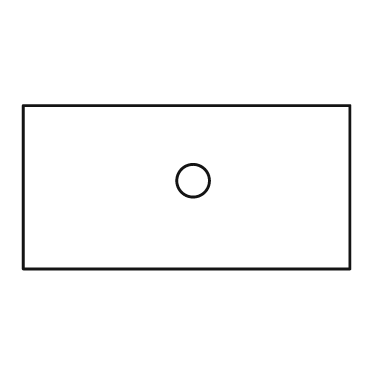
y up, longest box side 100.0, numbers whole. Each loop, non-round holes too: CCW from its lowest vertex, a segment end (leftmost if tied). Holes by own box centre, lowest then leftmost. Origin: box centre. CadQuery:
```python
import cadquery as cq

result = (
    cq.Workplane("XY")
    .moveTo(-50.0, -25.0)
    .lineTo(50.0, -25.0)
    .lineTo(50.0, 25.0)
    .lineTo(-50.0, 25.0)
    .close()
    .moveTo(2.0, 2.0)
    .circle(5.0)
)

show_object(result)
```